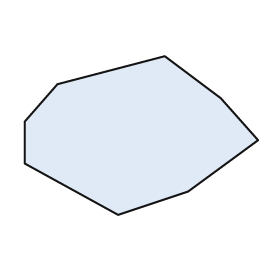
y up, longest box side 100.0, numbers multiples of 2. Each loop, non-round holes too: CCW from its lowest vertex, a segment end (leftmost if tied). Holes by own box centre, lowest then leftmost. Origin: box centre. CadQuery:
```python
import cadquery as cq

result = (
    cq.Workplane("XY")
    .moveTo(-10.0, -34.0)
    .lineTo(20.0, -24.0)
    .lineTo(50.0, -2.0)
    .lineTo(34.0, 16.0)
    .lineTo(10.0, 34.0)
    .lineTo(-36.0, 22.0)
    .lineTo(-50.0, 6.0)
    .lineTo(-50.0, -12.0)
    .close()
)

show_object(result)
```